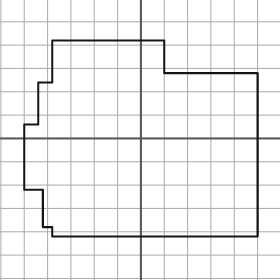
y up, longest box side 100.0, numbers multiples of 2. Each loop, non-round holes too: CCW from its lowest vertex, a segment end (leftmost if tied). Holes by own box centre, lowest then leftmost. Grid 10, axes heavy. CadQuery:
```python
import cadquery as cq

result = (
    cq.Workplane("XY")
    .moveTo(-38.0, -42.0)
    .lineTo(50.0, -42.0)
    .lineTo(50.0, 28.0)
    .lineTo(10.0, 28.0)
    .lineTo(10.0, 42.0)
    .lineTo(-38.0, 42.0)
    .lineTo(-38.0, 24.0)
    .lineTo(-44.0, 24.0)
    .lineTo(-44.0, 6.0)
    .lineTo(-50.0, 6.0)
    .lineTo(-50.0, -22.0)
    .lineTo(-42.0, -22.0)
    .lineTo(-42.0, -38.0)
    .lineTo(-38.0, -38.0)
    .close()
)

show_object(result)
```